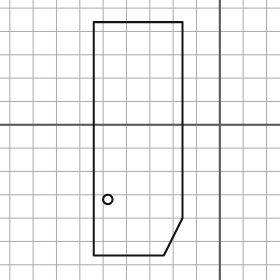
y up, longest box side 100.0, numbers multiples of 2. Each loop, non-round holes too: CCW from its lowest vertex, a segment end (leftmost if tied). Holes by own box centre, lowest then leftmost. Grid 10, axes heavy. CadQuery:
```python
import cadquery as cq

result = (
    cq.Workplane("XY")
    .moveTo(-54.0, -56.0)
    .lineTo(-24.0, -56.0)
    .lineTo(-16.0, -40.0)
    .lineTo(-16.0, 44.0)
    .lineTo(-54.0, 44.0)
    .close()
    .moveTo(-48.0, -32.0)
    .circle(2.0)
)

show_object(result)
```